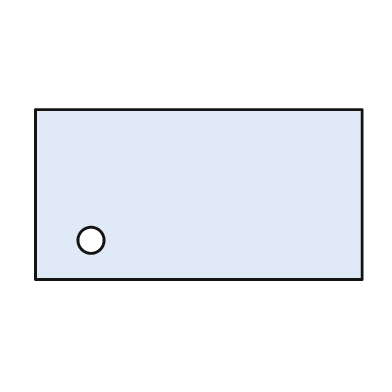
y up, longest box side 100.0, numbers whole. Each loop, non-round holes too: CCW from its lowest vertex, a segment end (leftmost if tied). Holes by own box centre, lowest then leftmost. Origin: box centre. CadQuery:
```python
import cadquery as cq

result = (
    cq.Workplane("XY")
    .moveTo(-50.0, -26.0)
    .lineTo(50.0, -26.0)
    .lineTo(50.0, 26.0)
    .lineTo(-50.0, 26.0)
    .close()
    .moveTo(-33.0, -14.0)
    .circle(4.0)
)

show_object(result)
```